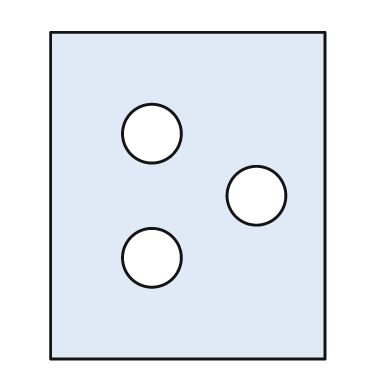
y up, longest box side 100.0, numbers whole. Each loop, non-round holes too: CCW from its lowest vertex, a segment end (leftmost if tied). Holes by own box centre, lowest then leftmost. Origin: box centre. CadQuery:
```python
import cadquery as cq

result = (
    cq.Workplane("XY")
    .moveTo(-42.0, -50.0)
    .lineTo(42.0, -50.0)
    .lineTo(42.0, 50.0)
    .lineTo(-42.0, 50.0)
    .close()
    .moveTo(-11.0, -19.0)
    .circle(9.0)
    .moveTo(21.0, 0.0)
    .circle(9.0)
    .moveTo(-11.0, 19.0)
    .circle(9.0)
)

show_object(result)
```